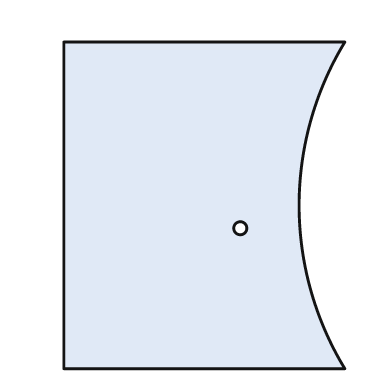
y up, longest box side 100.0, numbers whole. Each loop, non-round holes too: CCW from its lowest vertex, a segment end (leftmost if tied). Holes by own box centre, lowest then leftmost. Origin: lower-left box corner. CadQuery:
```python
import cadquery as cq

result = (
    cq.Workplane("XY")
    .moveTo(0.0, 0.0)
    .lineTo(86.0, 0.0)
    .threePointArc((72.0, 50.0), (86.0, 100.0))
    .lineTo(0.0, 100.0)
    .close()
    .moveTo(54.0, 43.0)
    .circle(2.0)
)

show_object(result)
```